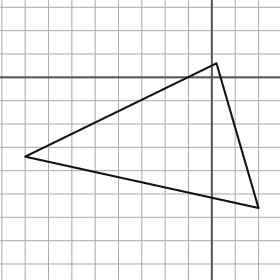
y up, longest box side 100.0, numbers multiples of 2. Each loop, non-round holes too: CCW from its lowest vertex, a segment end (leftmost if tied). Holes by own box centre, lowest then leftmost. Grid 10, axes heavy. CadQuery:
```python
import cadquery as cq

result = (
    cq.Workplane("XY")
    .moveTo(20.0, -56.0)
    .lineTo(2.0, 6.0)
    .lineTo(-80.0, -34.0)
    .close()
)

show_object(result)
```